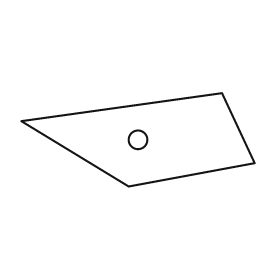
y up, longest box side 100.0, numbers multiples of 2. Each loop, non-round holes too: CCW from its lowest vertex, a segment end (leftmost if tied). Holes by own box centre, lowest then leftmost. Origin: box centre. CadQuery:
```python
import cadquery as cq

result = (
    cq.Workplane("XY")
    .moveTo(-4.0, -20.0)
    .lineTo(50.0, -10.0)
    .lineTo(36.0, 20.0)
    .lineTo(-50.0, 8.0)
    .close()
    .moveTo(0.0, 0.0)
    .circle(4.0)
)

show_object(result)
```